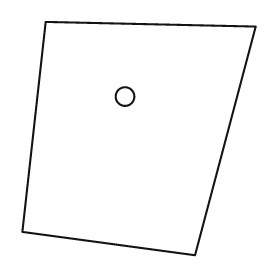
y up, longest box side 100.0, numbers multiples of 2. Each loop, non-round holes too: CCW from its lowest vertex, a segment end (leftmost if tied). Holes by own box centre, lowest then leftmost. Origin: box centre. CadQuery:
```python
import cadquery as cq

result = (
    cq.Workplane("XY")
    .moveTo(24.0, -50.0)
    .lineTo(50.0, 48.0)
    .lineTo(-40.0, 50.0)
    .lineTo(-50.0, -40.0)
    .close()
    .moveTo(-6.0, 18.0)
    .circle(4.0)
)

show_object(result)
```